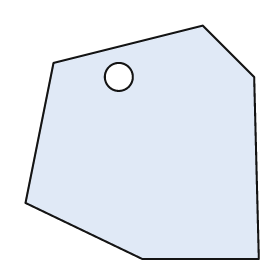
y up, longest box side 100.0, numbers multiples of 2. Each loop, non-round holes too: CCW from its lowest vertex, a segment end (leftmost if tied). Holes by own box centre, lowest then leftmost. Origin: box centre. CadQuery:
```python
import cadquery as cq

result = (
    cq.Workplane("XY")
    .moveTo(0.0, -50.0)
    .lineTo(50.0, -50.0)
    .lineTo(48.0, 28.0)
    .lineTo(26.0, 50.0)
    .lineTo(-38.0, 34.0)
    .lineTo(-50.0, -26.0)
    .close()
    .moveTo(-10.0, 28.0)
    .circle(6.0)
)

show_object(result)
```